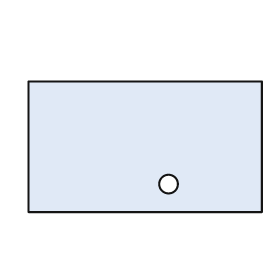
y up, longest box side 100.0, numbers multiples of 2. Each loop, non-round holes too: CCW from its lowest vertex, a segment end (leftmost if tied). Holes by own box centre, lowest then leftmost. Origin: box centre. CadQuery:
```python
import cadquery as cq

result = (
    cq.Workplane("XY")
    .moveTo(-50.0, -28.0)
    .lineTo(50.0, -28.0)
    .lineTo(50.0, 28.0)
    .lineTo(-50.0, 28.0)
    .close()
    .moveTo(10.0, -16.0)
    .circle(4.0)
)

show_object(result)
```